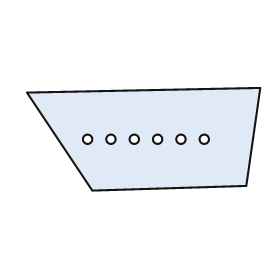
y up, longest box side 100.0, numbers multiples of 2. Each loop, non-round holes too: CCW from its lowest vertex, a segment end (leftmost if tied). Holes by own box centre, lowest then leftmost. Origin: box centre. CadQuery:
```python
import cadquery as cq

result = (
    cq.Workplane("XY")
    .moveTo(-22.0, -22.0)
    .lineTo(44.0, -20.0)
    .lineTo(50.0, 22.0)
    .lineTo(-50.0, 20.0)
    .close()
    .moveTo(-24.0, 0.0)
    .circle(2.0)
    .moveTo(-14.0, 0.0)
    .circle(2.0)
    .moveTo(-4.0, 0.0)
    .circle(2.0)
    .moveTo(6.0, 0.0)
    .circle(2.0)
    .moveTo(16.0, 0.0)
    .circle(2.0)
    .moveTo(26.0, 0.0)
    .circle(2.0)
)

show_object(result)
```